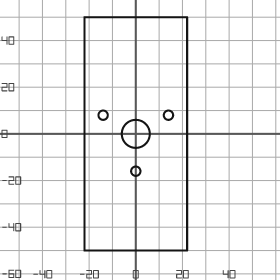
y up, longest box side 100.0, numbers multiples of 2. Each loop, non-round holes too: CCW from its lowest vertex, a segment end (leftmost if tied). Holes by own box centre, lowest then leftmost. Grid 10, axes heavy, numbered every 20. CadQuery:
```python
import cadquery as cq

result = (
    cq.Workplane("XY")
    .moveTo(-22.0, -50.0)
    .lineTo(22.0, -50.0)
    .lineTo(22.0, 50.0)
    .lineTo(-22.0, 50.0)
    .close()
    .moveTo(0.0, -16.0)
    .circle(2.0)
    .moveTo(0.0, 0.0)
    .circle(6.0)
    .moveTo(-14.0, 8.0)
    .circle(2.0)
    .moveTo(14.0, 8.0)
    .circle(2.0)
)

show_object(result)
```